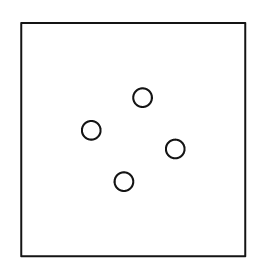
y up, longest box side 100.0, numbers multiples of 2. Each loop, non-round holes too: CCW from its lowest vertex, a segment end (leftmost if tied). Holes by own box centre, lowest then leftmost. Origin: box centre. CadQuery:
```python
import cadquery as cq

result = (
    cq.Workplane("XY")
    .moveTo(-48.0, -50.0)
    .lineTo(48.0, -50.0)
    .lineTo(48.0, 50.0)
    .lineTo(-48.0, 50.0)
    .close()
    .moveTo(-4.0, -18.0)
    .circle(4.0)
    .moveTo(18.0, -4.0)
    .circle(4.0)
    .moveTo(-18.0, 4.0)
    .circle(4.0)
    .moveTo(4.0, 18.0)
    .circle(4.0)
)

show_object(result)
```